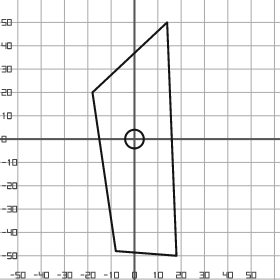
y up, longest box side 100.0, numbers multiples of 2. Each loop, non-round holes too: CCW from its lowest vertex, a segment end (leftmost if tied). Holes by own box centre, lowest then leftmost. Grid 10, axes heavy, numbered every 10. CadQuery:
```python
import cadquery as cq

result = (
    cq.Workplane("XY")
    .moveTo(18.0, -50.0)
    .lineTo(14.0, 50.0)
    .lineTo(-18.0, 20.0)
    .lineTo(-8.0, -48.0)
    .close()
    .moveTo(0.0, 0.0)
    .circle(4.0)
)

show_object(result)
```